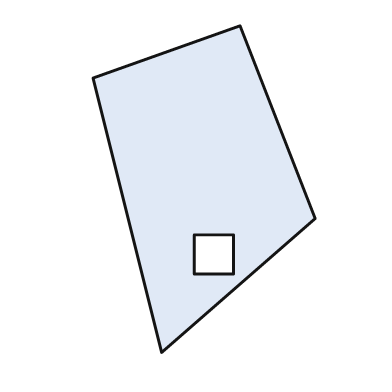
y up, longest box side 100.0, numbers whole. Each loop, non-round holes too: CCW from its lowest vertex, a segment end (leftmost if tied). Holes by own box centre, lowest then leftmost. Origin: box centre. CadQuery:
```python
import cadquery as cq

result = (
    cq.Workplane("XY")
    .moveTo(-13.0, -50.0)
    .lineTo(34.0, -9.0)
    .lineTo(11.0, 50.0)
    .lineTo(-34.0, 34.0)
    .close()
    .moveTo(-3.0, -26.0)
    .lineTo(9.0, -26.0)
    .lineTo(9.0, -14.0)
    .lineTo(-3.0, -14.0)
    .close()
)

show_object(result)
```